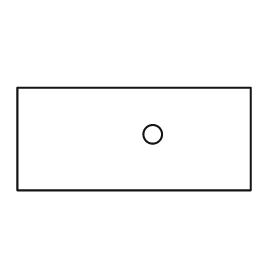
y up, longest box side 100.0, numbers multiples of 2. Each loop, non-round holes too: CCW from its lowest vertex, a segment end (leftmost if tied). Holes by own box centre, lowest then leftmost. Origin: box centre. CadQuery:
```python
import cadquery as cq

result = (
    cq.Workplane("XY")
    .moveTo(-50.0, -22.0)
    .lineTo(50.0, -22.0)
    .lineTo(50.0, 22.0)
    .lineTo(-50.0, 22.0)
    .close()
    .moveTo(8.0, 2.0)
    .circle(4.0)
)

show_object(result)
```